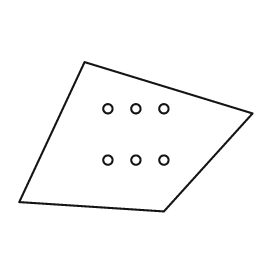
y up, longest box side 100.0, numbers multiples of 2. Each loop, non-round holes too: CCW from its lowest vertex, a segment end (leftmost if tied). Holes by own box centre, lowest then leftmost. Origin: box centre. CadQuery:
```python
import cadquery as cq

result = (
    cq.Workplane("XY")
    .moveTo(12.0, -32.0)
    .lineTo(50.0, 10.0)
    .lineTo(-22.0, 32.0)
    .lineTo(-50.0, -28.0)
    .close()
    .moveTo(-12.0, -10.0)
    .circle(2.0)
    .moveTo(0.0, -10.0)
    .circle(2.0)
    .moveTo(12.0, -10.0)
    .circle(2.0)
    .moveTo(-12.0, 12.0)
    .circle(2.0)
    .moveTo(0.0, 12.0)
    .circle(2.0)
    .moveTo(12.0, 12.0)
    .circle(2.0)
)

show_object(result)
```